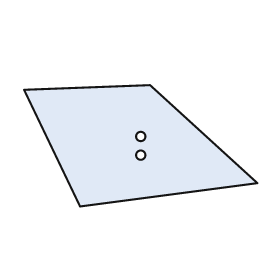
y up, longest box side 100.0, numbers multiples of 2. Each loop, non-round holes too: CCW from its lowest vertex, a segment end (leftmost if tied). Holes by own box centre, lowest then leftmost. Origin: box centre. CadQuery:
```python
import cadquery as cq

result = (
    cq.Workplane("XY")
    .moveTo(-26.0, -26.0)
    .lineTo(50.0, -16.0)
    .lineTo(4.0, 26.0)
    .lineTo(-50.0, 24.0)
    .close()
    .moveTo(0.0, -4.0)
    .circle(2.0)
    .moveTo(0.0, 4.0)
    .circle(2.0)
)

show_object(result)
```